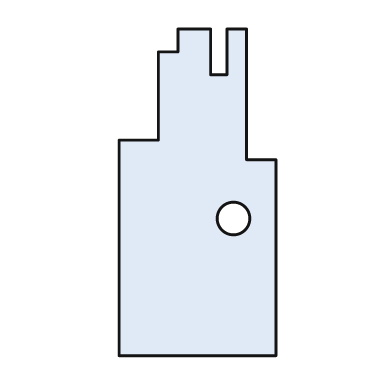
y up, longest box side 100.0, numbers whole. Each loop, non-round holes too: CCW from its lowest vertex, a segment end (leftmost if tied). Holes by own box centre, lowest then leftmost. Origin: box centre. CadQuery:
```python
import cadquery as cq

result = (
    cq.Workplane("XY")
    .moveTo(-24.0, -50.0)
    .lineTo(24.0, -50.0)
    .lineTo(24.0, 10.0)
    .lineTo(15.0, 10.0)
    .lineTo(15.0, 50.0)
    .lineTo(9.0, 50.0)
    .lineTo(9.0, 36.0)
    .lineTo(4.0, 36.0)
    .lineTo(4.0, 50.0)
    .lineTo(-6.0, 50.0)
    .lineTo(-6.0, 43.0)
    .lineTo(-12.0, 43.0)
    .lineTo(-12.0, 16.0)
    .lineTo(-24.0, 16.0)
    .close()
    .moveTo(11.0, -8.0)
    .circle(5.0)
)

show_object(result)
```